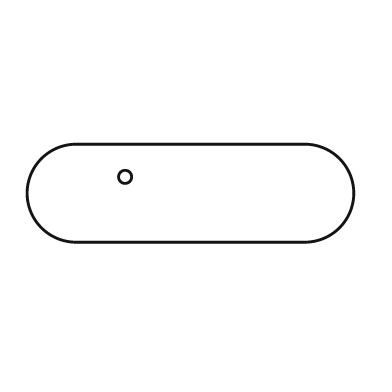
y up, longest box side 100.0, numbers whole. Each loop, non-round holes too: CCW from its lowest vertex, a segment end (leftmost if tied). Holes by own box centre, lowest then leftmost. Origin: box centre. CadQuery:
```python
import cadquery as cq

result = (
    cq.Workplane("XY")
    .moveTo(-35.0, -15.0)
    .lineTo(35.0, -15.0)
    .threePointArc((50.0, 0.0), (35.0, 15.0))
    .lineTo(-35.0, 15.0)
    .threePointArc((-50.0, 0.0), (-35.0, -15.0))
    .close()
    .moveTo(-20.0, 5.0)
    .circle(2.0)
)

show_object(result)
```